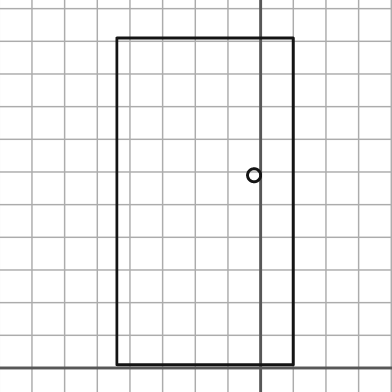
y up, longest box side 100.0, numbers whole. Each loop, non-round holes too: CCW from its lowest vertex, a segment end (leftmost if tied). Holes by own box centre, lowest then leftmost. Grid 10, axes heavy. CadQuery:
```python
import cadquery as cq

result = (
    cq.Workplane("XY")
    .moveTo(-44.0, 1.0)
    .lineTo(10.0, 1.0)
    .lineTo(10.0, 101.0)
    .lineTo(-44.0, 101.0)
    .close()
    .moveTo(-2.0, 59.0)
    .circle(2.0)
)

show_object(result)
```